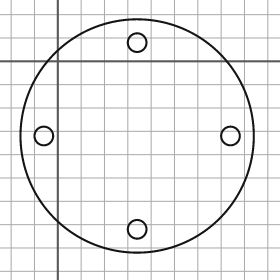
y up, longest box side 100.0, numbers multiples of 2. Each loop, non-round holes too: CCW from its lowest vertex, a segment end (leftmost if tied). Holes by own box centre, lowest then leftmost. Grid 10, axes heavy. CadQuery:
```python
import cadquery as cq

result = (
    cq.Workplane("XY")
    .moveTo(34.0, -32.0)
    .circle(50.0)
    .moveTo(34.0, -72.0)
    .circle(4.0)
    .moveTo(-6.0, -32.0)
    .circle(4.0)
    .moveTo(74.0, -32.0)
    .circle(4.0)
    .moveTo(34.0, 8.0)
    .circle(4.0)
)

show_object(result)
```